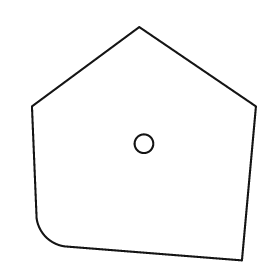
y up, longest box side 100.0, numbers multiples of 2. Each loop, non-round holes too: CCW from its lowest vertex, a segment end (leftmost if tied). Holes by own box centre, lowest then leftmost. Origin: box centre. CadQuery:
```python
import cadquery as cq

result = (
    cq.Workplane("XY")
    .moveTo(42.0, -50.0)
    .lineTo(48.0, 16.0)
    .lineTo(-2.0, 50.0)
    .lineTo(-48.0, 16.0)
    .lineTo(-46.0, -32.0)
    .threePointArc((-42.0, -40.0), (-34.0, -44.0))
    .close()
    .moveTo(0.0, 0.0)
    .circle(4.0)
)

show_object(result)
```